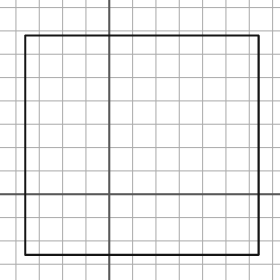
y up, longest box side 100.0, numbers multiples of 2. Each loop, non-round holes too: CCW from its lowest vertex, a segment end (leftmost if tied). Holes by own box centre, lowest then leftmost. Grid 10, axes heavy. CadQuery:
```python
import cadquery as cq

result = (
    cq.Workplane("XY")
    .moveTo(-36.0, -26.0)
    .lineTo(64.0, -26.0)
    .lineTo(64.0, 68.0)
    .lineTo(-36.0, 68.0)
    .close()
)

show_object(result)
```